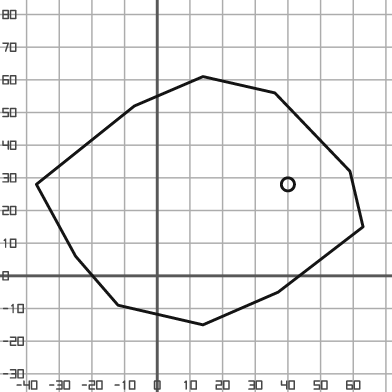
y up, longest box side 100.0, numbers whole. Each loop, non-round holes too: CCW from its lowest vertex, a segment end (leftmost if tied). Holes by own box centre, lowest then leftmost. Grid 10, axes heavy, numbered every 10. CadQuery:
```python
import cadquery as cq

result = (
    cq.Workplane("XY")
    .moveTo(14.0, -15.0)
    .lineTo(37.0, -5.0)
    .lineTo(63.0, 15.0)
    .lineTo(59.0, 32.0)
    .lineTo(36.0, 56.0)
    .lineTo(14.0, 61.0)
    .lineTo(-7.0, 52.0)
    .lineTo(-37.0, 28.0)
    .lineTo(-25.0, 6.0)
    .lineTo(-12.0, -9.0)
    .close()
    .moveTo(40.0, 28.0)
    .circle(2.0)
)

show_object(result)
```